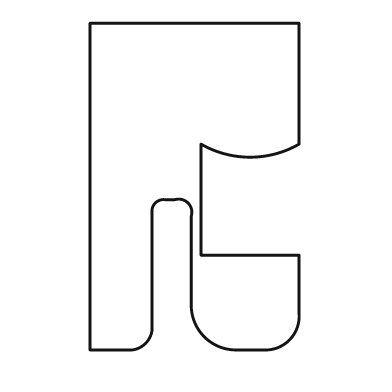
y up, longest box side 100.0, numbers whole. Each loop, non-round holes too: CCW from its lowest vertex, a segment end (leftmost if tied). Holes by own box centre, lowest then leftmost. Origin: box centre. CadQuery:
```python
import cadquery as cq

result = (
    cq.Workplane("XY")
    .moveTo(-32.0, -50.0)
    .lineTo(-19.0, -50.0)
    .threePointArc((-15.0, -48.0), (-13.0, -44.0))
    .lineTo(-13.0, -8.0)
    .threePointArc((-12.0, -5.0), (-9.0, -4.0))
    .lineTo(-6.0, -4.0)
    .threePointArc((-2.0, -5.0), (-1.0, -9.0))
    .lineTo(-1.0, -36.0)
    .threePointArc((3.0, -46.0), (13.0, -50.0))
    .lineTo(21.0, -50.0)
    .threePointArc((29.0, -47.0), (32.0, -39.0))
    .lineTo(32.0, -21.0)
    .lineTo(2.0, -21.0)
    .lineTo(2.0, 13.0)
    .threePointArc((17.0, 9.0), (32.0, 13.0))
    .lineTo(32.0, 50.0)
    .lineTo(-32.0, 50.0)
    .close()
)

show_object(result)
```